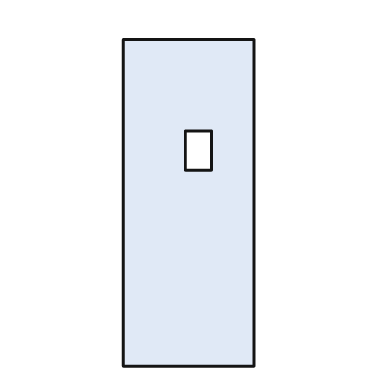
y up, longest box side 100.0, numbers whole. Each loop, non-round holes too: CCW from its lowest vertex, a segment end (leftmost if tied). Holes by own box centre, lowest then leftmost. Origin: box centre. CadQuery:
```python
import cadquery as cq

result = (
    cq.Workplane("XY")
    .moveTo(-20.0, -50.0)
    .lineTo(20.0, -50.0)
    .lineTo(20.0, 50.0)
    .lineTo(-20.0, 50.0)
    .close()
    .moveTo(-1.0, 10.0)
    .lineTo(7.0, 10.0)
    .lineTo(7.0, 22.0)
    .lineTo(-1.0, 22.0)
    .close()
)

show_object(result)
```